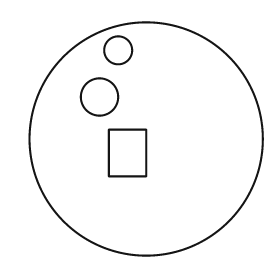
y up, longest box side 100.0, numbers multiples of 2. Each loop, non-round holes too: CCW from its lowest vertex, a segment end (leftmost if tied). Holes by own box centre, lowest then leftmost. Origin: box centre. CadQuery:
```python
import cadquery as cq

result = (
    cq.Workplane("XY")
    .moveTo(0.0, 0.0)
    .circle(50.0)
    .moveTo(-16.0, -16.0)
    .lineTo(0.0, -16.0)
    .lineTo(0.0, 4.0)
    .lineTo(-16.0, 4.0)
    .close()
    .moveTo(-20.0, 18.0)
    .circle(8.0)
    .moveTo(-12.0, 38.0)
    .circle(6.0)
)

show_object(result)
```